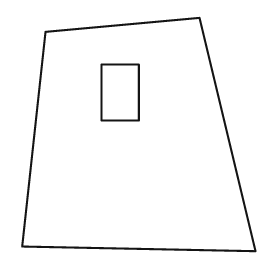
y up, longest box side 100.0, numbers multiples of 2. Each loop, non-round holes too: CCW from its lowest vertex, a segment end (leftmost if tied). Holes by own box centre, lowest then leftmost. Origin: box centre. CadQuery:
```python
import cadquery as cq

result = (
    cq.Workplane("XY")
    .moveTo(50.0, -50.0)
    .lineTo(26.0, 50.0)
    .lineTo(-40.0, 44.0)
    .lineTo(-50.0, -48.0)
    .close()
    .moveTo(-16.0, 6.0)
    .lineTo(0.0, 6.0)
    .lineTo(0.0, 30.0)
    .lineTo(-16.0, 30.0)
    .close()
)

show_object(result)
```